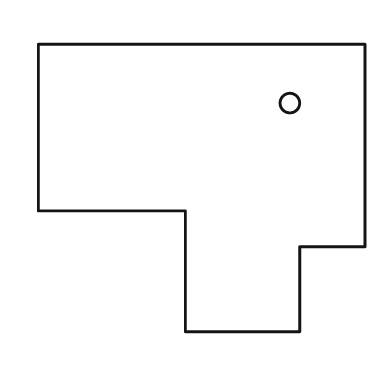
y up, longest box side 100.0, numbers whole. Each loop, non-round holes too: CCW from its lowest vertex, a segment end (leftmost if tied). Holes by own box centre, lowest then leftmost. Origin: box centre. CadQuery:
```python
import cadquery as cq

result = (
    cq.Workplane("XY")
    .moveTo(-5.0, -44.0)
    .lineTo(30.0, -44.0)
    .lineTo(30.0, -18.0)
    .lineTo(50.0, -18.0)
    .lineTo(50.0, 44.0)
    .lineTo(-50.0, 44.0)
    .lineTo(-50.0, -7.0)
    .lineTo(-5.0, -7.0)
    .close()
    .moveTo(27.0, 26.0)
    .circle(3.0)
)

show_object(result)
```